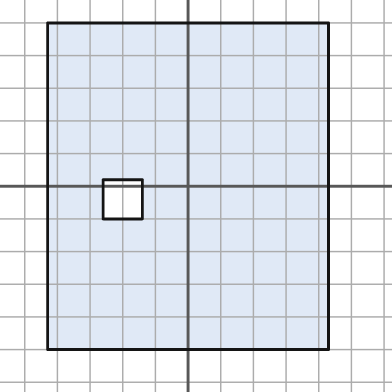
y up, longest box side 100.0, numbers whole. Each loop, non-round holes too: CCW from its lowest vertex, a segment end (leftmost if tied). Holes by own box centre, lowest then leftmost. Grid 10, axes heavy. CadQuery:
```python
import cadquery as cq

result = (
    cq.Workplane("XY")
    .moveTo(-43.0, -50.0)
    .lineTo(43.0, -50.0)
    .lineTo(43.0, 50.0)
    .lineTo(-43.0, 50.0)
    .close()
    .moveTo(-26.0, -10.0)
    .lineTo(-14.0, -10.0)
    .lineTo(-14.0, 2.0)
    .lineTo(-26.0, 2.0)
    .close()
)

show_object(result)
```